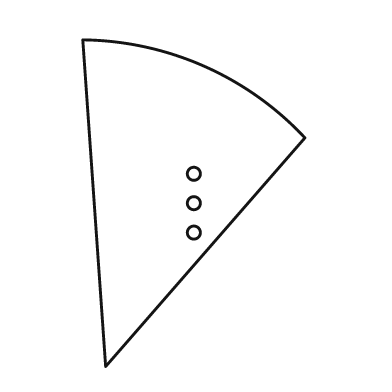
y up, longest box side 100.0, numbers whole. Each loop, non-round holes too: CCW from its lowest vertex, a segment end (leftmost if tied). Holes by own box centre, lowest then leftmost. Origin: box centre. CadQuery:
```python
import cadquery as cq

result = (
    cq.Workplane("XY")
    .moveTo(-27.0, -50.0)
    .lineTo(34.0, 20.0)
    .threePointArc((3.0, 42.0), (-34.0, 50.0))
    .close()
    .moveTo(0.0, -9.0)
    .circle(2.0)
    .moveTo(0.0, 0.0)
    .circle(2.0)
    .moveTo(0.0, 9.0)
    .circle(2.0)
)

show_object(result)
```